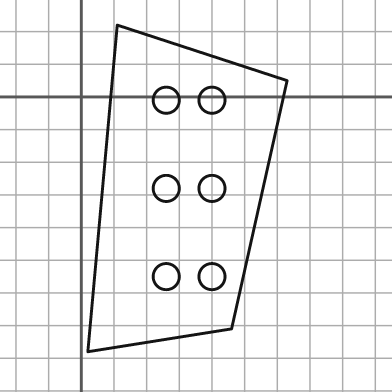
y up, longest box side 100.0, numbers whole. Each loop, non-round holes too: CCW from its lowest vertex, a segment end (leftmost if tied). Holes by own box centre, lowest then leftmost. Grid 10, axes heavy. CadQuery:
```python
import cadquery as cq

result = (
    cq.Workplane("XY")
    .moveTo(2.0, -78.0)
    .lineTo(46.0, -71.0)
    .lineTo(63.0, 5.0)
    .lineTo(11.0, 22.0)
    .close()
    .moveTo(26.0, -55.0)
    .circle(4.0)
    .moveTo(40.0, -55.0)
    .circle(4.0)
    .moveTo(26.0, -28.0)
    .circle(4.0)
    .moveTo(40.0, -28.0)
    .circle(4.0)
    .moveTo(26.0, -1.0)
    .circle(4.0)
    .moveTo(40.0, -1.0)
    .circle(4.0)
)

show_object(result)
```